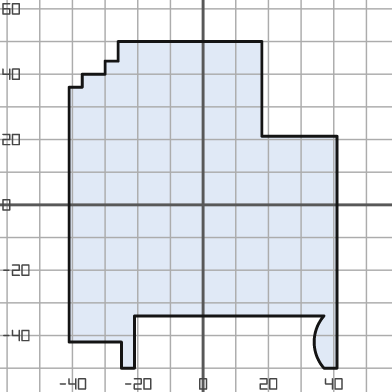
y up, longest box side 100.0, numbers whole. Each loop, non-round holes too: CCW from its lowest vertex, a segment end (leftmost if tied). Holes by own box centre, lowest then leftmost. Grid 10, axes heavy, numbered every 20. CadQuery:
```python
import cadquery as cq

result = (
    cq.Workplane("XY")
    .moveTo(-25.0, -50.0)
    .lineTo(-21.0, -50.0)
    .lineTo(-21.0, -34.0)
    .lineTo(37.0, -34.0)
    .threePointArc((34.0, -42.0), (37.0, -50.0))
    .lineTo(41.0, -50.0)
    .lineTo(41.0, 21.0)
    .lineTo(18.0, 21.0)
    .lineTo(18.0, 50.0)
    .lineTo(-26.0, 50.0)
    .lineTo(-26.0, 44.0)
    .lineTo(-30.0, 44.0)
    .lineTo(-30.0, 40.0)
    .lineTo(-37.0, 40.0)
    .lineTo(-37.0, 36.0)
    .lineTo(-41.0, 36.0)
    .lineTo(-41.0, -42.0)
    .lineTo(-25.0, -42.0)
    .close()
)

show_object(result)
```